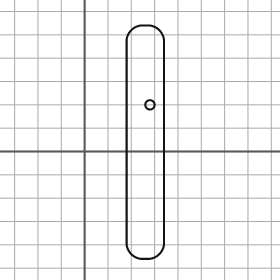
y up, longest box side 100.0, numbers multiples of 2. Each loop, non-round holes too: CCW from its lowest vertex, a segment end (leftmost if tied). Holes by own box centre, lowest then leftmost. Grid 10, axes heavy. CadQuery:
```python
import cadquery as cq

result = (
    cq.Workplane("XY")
    .moveTo(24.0, -46.0)
    .lineTo(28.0, -46.0)
    .threePointArc((32.0, -44.0), (34.0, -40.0))
    .lineTo(34.0, 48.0)
    .threePointArc((32.0, 52.0), (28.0, 54.0))
    .lineTo(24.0, 54.0)
    .threePointArc((20.0, 52.0), (18.0, 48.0))
    .lineTo(18.0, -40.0)
    .threePointArc((20.0, -44.0), (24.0, -46.0))
    .close()
    .moveTo(28.0, 20.0)
    .circle(2.0)
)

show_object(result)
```